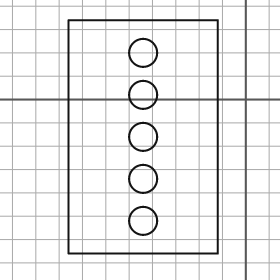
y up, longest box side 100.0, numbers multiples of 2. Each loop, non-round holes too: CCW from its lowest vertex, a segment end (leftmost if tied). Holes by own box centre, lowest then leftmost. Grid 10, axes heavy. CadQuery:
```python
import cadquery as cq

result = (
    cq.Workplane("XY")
    .moveTo(-76.0, -66.0)
    .lineTo(-12.0, -66.0)
    .lineTo(-12.0, 34.0)
    .lineTo(-76.0, 34.0)
    .close()
    .moveTo(-44.0, -52.0)
    .circle(6.0)
    .moveTo(-44.0, -34.0)
    .circle(6.0)
    .moveTo(-44.0, -16.0)
    .circle(6.0)
    .moveTo(-44.0, 2.0)
    .circle(6.0)
    .moveTo(-44.0, 20.0)
    .circle(6.0)
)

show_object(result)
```